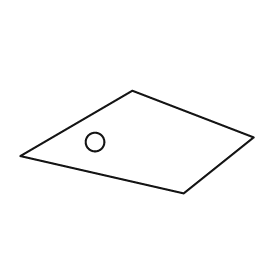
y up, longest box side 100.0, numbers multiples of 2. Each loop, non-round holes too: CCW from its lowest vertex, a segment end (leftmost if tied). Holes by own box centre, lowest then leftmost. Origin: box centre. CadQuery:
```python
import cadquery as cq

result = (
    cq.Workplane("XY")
    .moveTo(20.0, -22.0)
    .lineTo(50.0, 2.0)
    .lineTo(-2.0, 22.0)
    .lineTo(-50.0, -6.0)
    .close()
    .moveTo(-18.0, 0.0)
    .circle(4.0)
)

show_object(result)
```